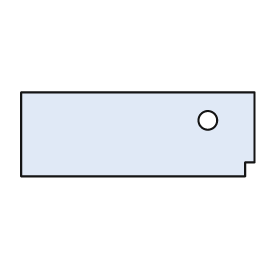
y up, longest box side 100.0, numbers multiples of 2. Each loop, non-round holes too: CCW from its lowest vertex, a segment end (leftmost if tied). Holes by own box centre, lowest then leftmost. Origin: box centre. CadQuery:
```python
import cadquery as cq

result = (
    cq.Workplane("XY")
    .moveTo(-50.0, -18.0)
    .lineTo(46.0, -18.0)
    .lineTo(46.0, -12.0)
    .lineTo(50.0, -12.0)
    .lineTo(50.0, 18.0)
    .lineTo(-50.0, 18.0)
    .close()
    .moveTo(30.0, 6.0)
    .circle(4.0)
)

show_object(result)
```